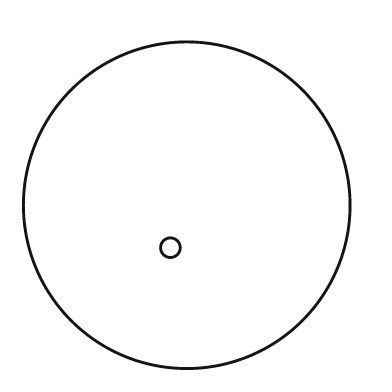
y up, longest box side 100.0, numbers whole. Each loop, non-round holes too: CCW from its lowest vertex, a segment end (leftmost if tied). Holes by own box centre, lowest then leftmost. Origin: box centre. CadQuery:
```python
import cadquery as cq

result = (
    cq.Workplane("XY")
    .moveTo(0.0, 0.0)
    .circle(50.0)
    .moveTo(-5.0, -13.0)
    .circle(3.0)
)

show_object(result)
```